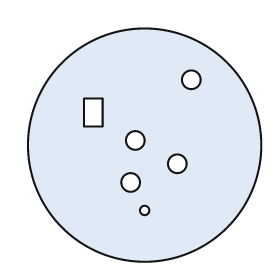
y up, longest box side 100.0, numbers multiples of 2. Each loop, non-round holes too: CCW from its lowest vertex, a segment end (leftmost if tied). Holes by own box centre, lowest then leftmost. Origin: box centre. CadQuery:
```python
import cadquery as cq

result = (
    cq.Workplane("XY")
    .moveTo(0.0, 0.0)
    .circle(50.0)
    .moveTo(0.0, -28.0)
    .circle(2.0)
    .moveTo(-6.0, -16.0)
    .circle(4.0)
    .moveTo(14.0, -8.0)
    .circle(4.0)
    .moveTo(-4.0, 2.0)
    .circle(4.0)
    .moveTo(-26.0, 8.0)
    .lineTo(-18.0, 8.0)
    .lineTo(-18.0, 20.0)
    .lineTo(-26.0, 20.0)
    .close()
    .moveTo(20.0, 28.0)
    .circle(4.0)
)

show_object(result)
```